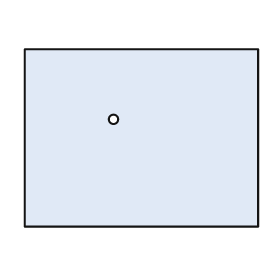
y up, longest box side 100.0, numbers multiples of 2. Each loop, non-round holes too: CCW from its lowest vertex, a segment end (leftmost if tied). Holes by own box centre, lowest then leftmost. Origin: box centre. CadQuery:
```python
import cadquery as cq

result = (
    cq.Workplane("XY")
    .moveTo(-50.0, -38.0)
    .lineTo(50.0, -38.0)
    .lineTo(50.0, 38.0)
    .lineTo(-50.0, 38.0)
    .close()
    .moveTo(-12.0, 8.0)
    .circle(2.0)
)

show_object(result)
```